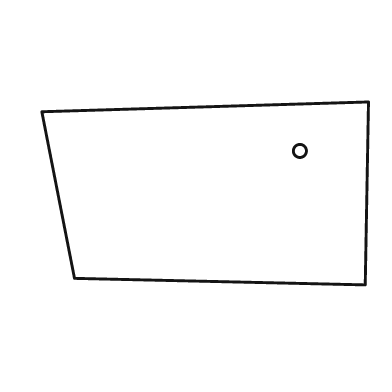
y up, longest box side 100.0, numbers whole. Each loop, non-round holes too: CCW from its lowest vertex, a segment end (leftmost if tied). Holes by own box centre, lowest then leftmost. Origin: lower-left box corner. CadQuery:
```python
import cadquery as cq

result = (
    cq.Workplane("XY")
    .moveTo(99.0, 0.0)
    .lineTo(100.0, 56.0)
    .lineTo(0.0, 53.0)
    .lineTo(10.0, 2.0)
    .close()
    .moveTo(79.0, 41.0)
    .circle(2.0)
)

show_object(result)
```